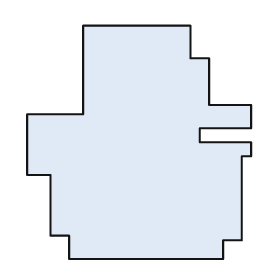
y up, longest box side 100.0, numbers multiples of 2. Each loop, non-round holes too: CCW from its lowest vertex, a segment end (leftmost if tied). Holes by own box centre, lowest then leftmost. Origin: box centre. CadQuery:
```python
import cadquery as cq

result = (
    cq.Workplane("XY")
    .moveTo(-30.0, -50.0)
    .lineTo(36.0, -50.0)
    .lineTo(36.0, -42.0)
    .lineTo(44.0, -42.0)
    .lineTo(44.0, -6.0)
    .lineTo(48.0, -6.0)
    .lineTo(48.0, 0.0)
    .lineTo(26.0, 0.0)
    .lineTo(26.0, 6.0)
    .lineTo(48.0, 6.0)
    .lineTo(48.0, 16.0)
    .lineTo(30.0, 16.0)
    .lineTo(30.0, 36.0)
    .lineTo(22.0, 36.0)
    .lineTo(22.0, 50.0)
    .lineTo(-24.0, 50.0)
    .lineTo(-24.0, 12.0)
    .lineTo(-48.0, 12.0)
    .lineTo(-48.0, -14.0)
    .lineTo(-38.0, -14.0)
    .lineTo(-38.0, -40.0)
    .lineTo(-30.0, -40.0)
    .close()
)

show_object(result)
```